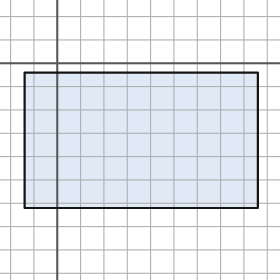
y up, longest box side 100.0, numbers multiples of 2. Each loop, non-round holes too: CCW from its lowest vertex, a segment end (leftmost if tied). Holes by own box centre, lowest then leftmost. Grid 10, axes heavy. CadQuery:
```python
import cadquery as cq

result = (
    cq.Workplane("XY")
    .moveTo(-14.0, -62.0)
    .lineTo(86.0, -62.0)
    .lineTo(86.0, -4.0)
    .lineTo(-14.0, -4.0)
    .close()
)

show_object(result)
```